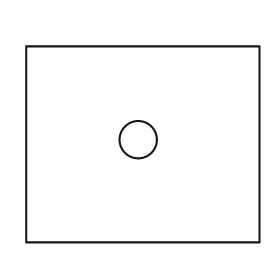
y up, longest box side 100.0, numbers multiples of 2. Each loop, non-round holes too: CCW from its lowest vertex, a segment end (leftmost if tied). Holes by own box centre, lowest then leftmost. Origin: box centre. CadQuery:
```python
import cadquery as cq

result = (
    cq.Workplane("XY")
    .moveTo(-50.0, -42.0)
    .lineTo(50.0, -42.0)
    .lineTo(50.0, 42.0)
    .lineTo(-50.0, 42.0)
    .close()
    .moveTo(-2.0, 2.0)
    .circle(8.0)
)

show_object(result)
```